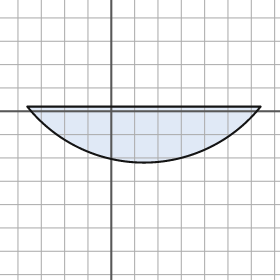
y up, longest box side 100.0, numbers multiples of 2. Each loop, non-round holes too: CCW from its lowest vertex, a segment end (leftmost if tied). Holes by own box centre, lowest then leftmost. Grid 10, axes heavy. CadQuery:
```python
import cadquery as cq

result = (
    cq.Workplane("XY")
    .moveTo(-36.0, 2.0)
    .threePointArc((14.0, -22.0), (64.0, 2.0))
    .close()
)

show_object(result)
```